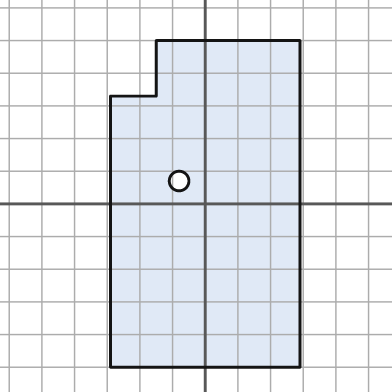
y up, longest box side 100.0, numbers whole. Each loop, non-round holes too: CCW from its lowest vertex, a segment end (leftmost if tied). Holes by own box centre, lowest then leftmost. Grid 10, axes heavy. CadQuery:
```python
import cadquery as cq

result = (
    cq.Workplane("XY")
    .moveTo(-29.0, -50.0)
    .lineTo(29.0, -50.0)
    .lineTo(29.0, 50.0)
    .lineTo(-15.0, 50.0)
    .lineTo(-15.0, 33.0)
    .lineTo(-29.0, 33.0)
    .close()
    .moveTo(-8.0, 7.0)
    .circle(3.0)
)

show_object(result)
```